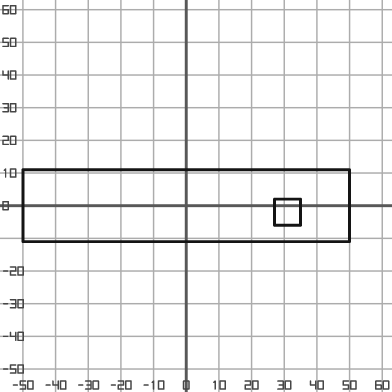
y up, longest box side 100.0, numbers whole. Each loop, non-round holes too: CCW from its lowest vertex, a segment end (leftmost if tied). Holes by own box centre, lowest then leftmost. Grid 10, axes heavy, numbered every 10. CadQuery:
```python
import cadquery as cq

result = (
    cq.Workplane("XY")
    .moveTo(-50.0, -11.0)
    .lineTo(50.0, -11.0)
    .lineTo(50.0, 11.0)
    .lineTo(-50.0, 11.0)
    .close()
    .moveTo(27.0, -6.0)
    .lineTo(35.0, -6.0)
    .lineTo(35.0, 2.0)
    .lineTo(27.0, 2.0)
    .close()
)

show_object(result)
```